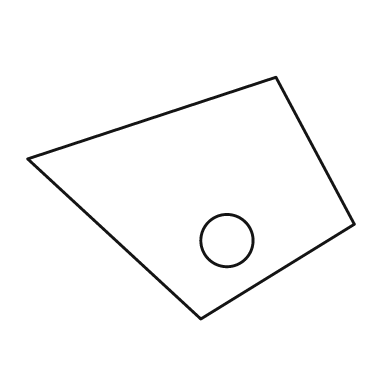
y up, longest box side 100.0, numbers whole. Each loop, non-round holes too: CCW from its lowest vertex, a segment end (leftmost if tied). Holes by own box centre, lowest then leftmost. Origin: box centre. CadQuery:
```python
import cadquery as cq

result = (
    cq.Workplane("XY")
    .moveTo(3.0, -37.0)
    .lineTo(50.0, -8.0)
    .lineTo(26.0, 37.0)
    .lineTo(-50.0, 12.0)
    .close()
    .moveTo(11.0, -13.0)
    .circle(8.0)
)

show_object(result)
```